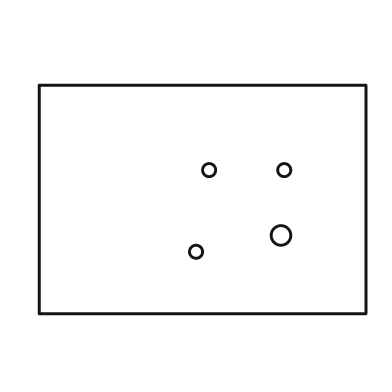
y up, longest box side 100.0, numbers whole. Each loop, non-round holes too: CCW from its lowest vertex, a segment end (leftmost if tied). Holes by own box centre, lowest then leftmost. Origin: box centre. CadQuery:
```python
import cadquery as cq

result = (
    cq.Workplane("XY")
    .moveTo(-50.0, -35.0)
    .lineTo(50.0, -35.0)
    .lineTo(50.0, 35.0)
    .lineTo(-50.0, 35.0)
    .close()
    .moveTo(-2.0, -16.0)
    .circle(2.0)
    .moveTo(24.0, -11.0)
    .circle(3.0)
    .moveTo(2.0, 9.0)
    .circle(2.0)
    .moveTo(25.0, 9.0)
    .circle(2.0)
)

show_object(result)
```